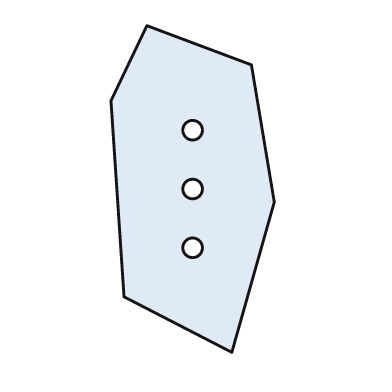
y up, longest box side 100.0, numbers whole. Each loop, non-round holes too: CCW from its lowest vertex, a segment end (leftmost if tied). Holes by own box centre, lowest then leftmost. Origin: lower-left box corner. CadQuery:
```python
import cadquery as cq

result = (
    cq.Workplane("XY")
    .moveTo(37.0, 0.0)
    .lineTo(50.0, 46.0)
    .lineTo(43.0, 88.0)
    .lineTo(11.0, 100.0)
    .lineTo(0.0, 77.0)
    .lineTo(4.0, 17.0)
    .close()
    .moveTo(25.0, 32.0)
    .circle(3.0)
    .moveTo(25.0, 50.0)
    .circle(3.0)
    .moveTo(25.0, 68.0)
    .circle(3.0)
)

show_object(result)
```